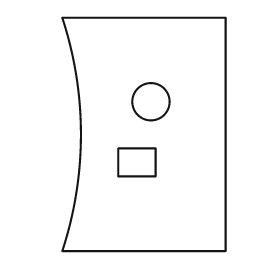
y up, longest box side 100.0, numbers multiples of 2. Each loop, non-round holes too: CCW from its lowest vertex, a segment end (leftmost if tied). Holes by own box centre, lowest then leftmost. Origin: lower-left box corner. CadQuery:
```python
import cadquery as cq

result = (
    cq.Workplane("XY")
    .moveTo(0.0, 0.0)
    .lineTo(70.0, 0.0)
    .lineTo(70.0, 100.0)
    .lineTo(0.0, 100.0)
    .threePointArc((8.0, 50.0), (0.0, 0.0))
    .close()
    .moveTo(24.0, 32.0)
    .lineTo(40.0, 32.0)
    .lineTo(40.0, 44.0)
    .lineTo(24.0, 44.0)
    .close()
    .moveTo(38.0, 64.0)
    .circle(8.0)
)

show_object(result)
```